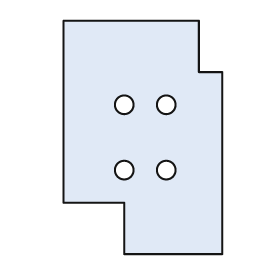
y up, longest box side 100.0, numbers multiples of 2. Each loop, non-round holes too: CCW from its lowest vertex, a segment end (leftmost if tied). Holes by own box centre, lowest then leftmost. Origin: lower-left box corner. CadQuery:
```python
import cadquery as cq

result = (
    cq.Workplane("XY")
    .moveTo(26.0, 0.0)
    .lineTo(68.0, 0.0)
    .lineTo(68.0, 78.0)
    .lineTo(58.0, 78.0)
    .lineTo(58.0, 100.0)
    .lineTo(0.0, 100.0)
    .lineTo(0.0, 22.0)
    .lineTo(26.0, 22.0)
    .close()
    .moveTo(26.0, 36.0)
    .circle(4.0)
    .moveTo(44.0, 36.0)
    .circle(4.0)
    .moveTo(26.0, 64.0)
    .circle(4.0)
    .moveTo(44.0, 64.0)
    .circle(4.0)
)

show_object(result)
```